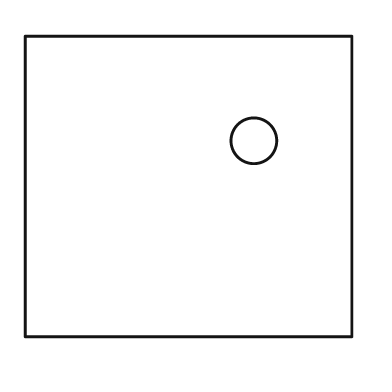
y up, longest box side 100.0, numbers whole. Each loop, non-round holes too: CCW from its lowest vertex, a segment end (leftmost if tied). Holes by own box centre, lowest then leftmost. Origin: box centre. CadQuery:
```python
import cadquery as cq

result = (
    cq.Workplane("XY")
    .moveTo(-50.0, -46.0)
    .lineTo(50.0, -46.0)
    .lineTo(50.0, 46.0)
    .lineTo(-50.0, 46.0)
    .close()
    .moveTo(20.0, 14.0)
    .circle(7.0)
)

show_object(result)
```